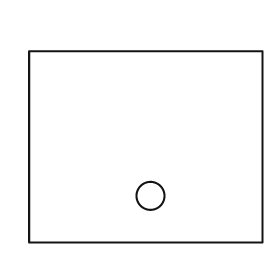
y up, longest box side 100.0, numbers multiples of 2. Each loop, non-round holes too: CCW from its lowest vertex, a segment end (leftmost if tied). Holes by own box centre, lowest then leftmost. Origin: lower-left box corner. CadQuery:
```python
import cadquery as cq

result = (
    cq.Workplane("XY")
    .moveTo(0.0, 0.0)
    .lineTo(100.0, 0.0)
    .lineTo(100.0, 82.0)
    .lineTo(0.0, 82.0)
    .close()
    .moveTo(52.0, 20.0)
    .circle(6.0)
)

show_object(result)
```